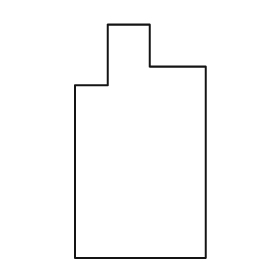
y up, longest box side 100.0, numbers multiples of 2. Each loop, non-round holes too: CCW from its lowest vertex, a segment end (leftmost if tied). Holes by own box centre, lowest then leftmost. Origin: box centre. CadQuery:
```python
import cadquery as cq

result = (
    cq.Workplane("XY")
    .moveTo(-28.0, -50.0)
    .lineTo(28.0, -50.0)
    .lineTo(28.0, 32.0)
    .lineTo(4.0, 32.0)
    .lineTo(4.0, 50.0)
    .lineTo(-14.0, 50.0)
    .lineTo(-14.0, 24.0)
    .lineTo(-28.0, 24.0)
    .close()
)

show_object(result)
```